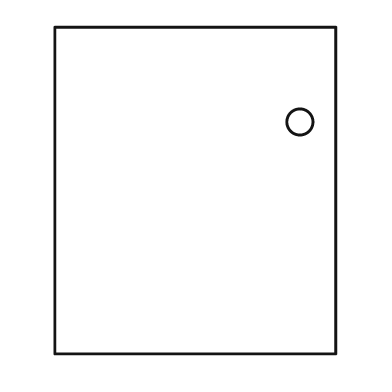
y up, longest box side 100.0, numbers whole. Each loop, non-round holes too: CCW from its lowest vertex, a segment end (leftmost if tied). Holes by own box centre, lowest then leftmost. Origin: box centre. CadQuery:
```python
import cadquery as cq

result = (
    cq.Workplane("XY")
    .moveTo(-43.0, -50.0)
    .lineTo(43.0, -50.0)
    .lineTo(43.0, 50.0)
    .lineTo(-43.0, 50.0)
    .close()
    .moveTo(32.0, 21.0)
    .circle(4.0)
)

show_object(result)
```